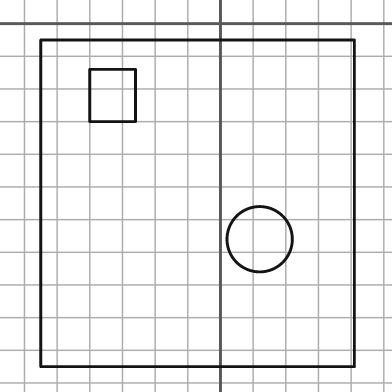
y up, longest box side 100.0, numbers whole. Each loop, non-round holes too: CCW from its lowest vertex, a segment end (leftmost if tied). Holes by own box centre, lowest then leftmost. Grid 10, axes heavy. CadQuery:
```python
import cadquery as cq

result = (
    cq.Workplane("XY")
    .moveTo(-55.0, -105.0)
    .lineTo(41.0, -105.0)
    .lineTo(41.0, -5.0)
    .lineTo(-55.0, -5.0)
    .close()
    .moveTo(12.0, -66.0)
    .circle(10.0)
    .moveTo(-40.0, -30.0)
    .lineTo(-26.0, -30.0)
    .lineTo(-26.0, -14.0)
    .lineTo(-40.0, -14.0)
    .close()
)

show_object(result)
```